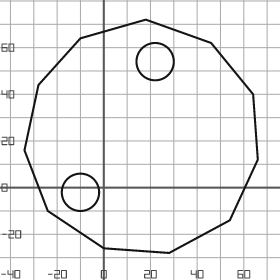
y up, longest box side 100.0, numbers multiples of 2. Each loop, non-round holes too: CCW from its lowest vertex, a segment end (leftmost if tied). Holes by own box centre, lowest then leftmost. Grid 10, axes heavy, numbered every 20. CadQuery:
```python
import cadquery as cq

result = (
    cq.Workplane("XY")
    .moveTo(28.0, -28.0)
    .lineTo(54.0, -14.0)
    .lineTo(66.0, 12.0)
    .lineTo(64.0, 40.0)
    .lineTo(46.0, 62.0)
    .lineTo(18.0, 72.0)
    .lineTo(-10.0, 64.0)
    .lineTo(-28.0, 44.0)
    .lineTo(-34.0, 16.0)
    .lineTo(-24.0, -10.0)
    .lineTo(0.0, -26.0)
    .close()
    .moveTo(-10.0, -2.0)
    .circle(8.0)
    .moveTo(22.0, 54.0)
    .circle(8.0)
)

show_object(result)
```